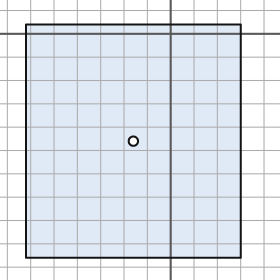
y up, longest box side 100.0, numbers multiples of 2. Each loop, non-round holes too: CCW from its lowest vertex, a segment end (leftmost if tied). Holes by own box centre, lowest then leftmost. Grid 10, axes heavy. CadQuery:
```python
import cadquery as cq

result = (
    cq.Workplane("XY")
    .moveTo(-62.0, -96.0)
    .lineTo(30.0, -96.0)
    .lineTo(30.0, 4.0)
    .lineTo(-62.0, 4.0)
    .close()
    .moveTo(-16.0, -46.0)
    .circle(2.0)
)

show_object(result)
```